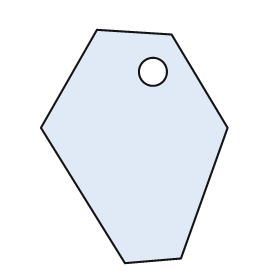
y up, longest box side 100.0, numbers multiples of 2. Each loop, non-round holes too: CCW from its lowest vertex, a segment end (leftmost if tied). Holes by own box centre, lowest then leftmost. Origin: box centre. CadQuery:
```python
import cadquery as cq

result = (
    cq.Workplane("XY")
    .moveTo(-4.0, -50.0)
    .lineTo(20.0, -48.0)
    .lineTo(40.0, 8.0)
    .lineTo(16.0, 48.0)
    .lineTo(-16.0, 50.0)
    .lineTo(-40.0, 8.0)
    .close()
    .moveTo(8.0, 32.0)
    .circle(6.0)
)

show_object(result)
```